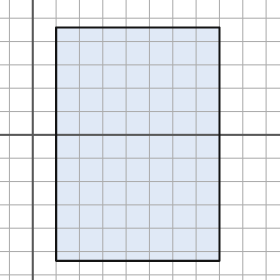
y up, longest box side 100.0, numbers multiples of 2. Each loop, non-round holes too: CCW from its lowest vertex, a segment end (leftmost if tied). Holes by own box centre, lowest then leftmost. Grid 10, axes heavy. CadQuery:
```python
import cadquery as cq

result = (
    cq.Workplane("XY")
    .moveTo(10.0, -54.0)
    .lineTo(80.0, -54.0)
    .lineTo(80.0, 46.0)
    .lineTo(10.0, 46.0)
    .close()
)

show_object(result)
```